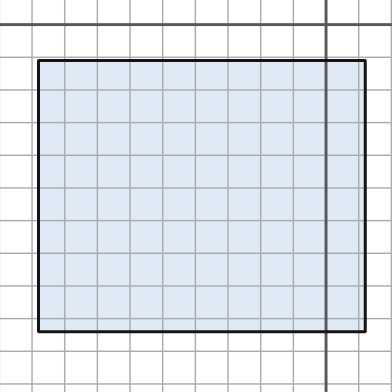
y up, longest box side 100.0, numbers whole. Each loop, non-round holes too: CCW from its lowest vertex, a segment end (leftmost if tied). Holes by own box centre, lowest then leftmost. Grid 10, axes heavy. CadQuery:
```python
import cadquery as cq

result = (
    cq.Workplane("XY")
    .moveTo(-88.0, -94.0)
    .lineTo(12.0, -94.0)
    .lineTo(12.0, -11.0)
    .lineTo(-88.0, -11.0)
    .close()
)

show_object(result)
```